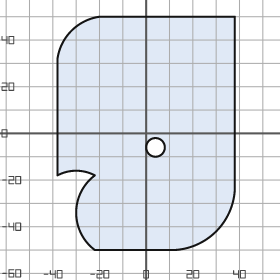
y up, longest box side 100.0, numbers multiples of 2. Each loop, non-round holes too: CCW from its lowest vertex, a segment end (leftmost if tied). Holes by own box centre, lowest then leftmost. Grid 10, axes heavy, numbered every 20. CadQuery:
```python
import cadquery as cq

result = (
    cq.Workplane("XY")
    .moveTo(-22.0, -50.0)
    .lineTo(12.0, -50.0)
    .threePointArc((30.0, -42.0), (38.0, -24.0))
    .lineTo(38.0, 50.0)
    .lineTo(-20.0, 50.0)
    .threePointArc((-32.0, 44.0), (-38.0, 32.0))
    .lineTo(-38.0, -18.0)
    .threePointArc((-30.0, -16.0), (-22.0, -18.0))
    .threePointArc((-30.0, -34.0), (-22.0, -50.0))
    .close()
    .moveTo(4.0, -6.0)
    .circle(4.0)
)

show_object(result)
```